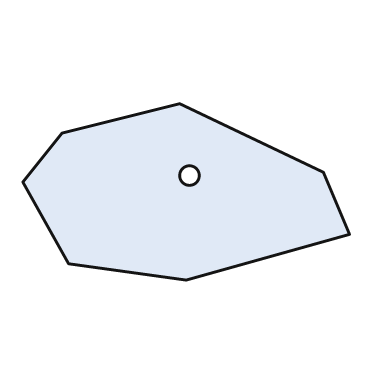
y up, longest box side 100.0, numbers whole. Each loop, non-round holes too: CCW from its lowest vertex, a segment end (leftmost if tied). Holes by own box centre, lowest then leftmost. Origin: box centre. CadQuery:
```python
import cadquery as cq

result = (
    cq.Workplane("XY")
    .moveTo(0.0, -27.0)
    .lineTo(50.0, -13.0)
    .lineTo(42.0, 6.0)
    .lineTo(-2.0, 27.0)
    .lineTo(-38.0, 18.0)
    .lineTo(-50.0, 3.0)
    .lineTo(-36.0, -22.0)
    .close()
    .moveTo(1.0, 5.0)
    .circle(3.0)
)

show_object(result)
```